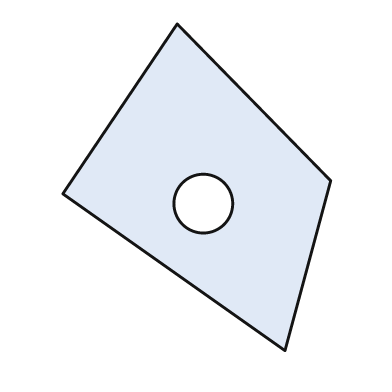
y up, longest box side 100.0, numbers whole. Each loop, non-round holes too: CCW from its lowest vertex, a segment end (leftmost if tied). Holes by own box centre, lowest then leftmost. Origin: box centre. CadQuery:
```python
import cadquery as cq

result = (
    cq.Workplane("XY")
    .moveTo(27.0, -50.0)
    .lineTo(41.0, 2.0)
    .lineTo(-6.0, 50.0)
    .lineTo(-41.0, -2.0)
    .close()
    .moveTo(2.0, -5.0)
    .circle(9.0)
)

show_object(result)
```